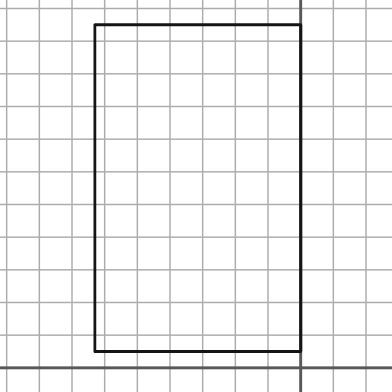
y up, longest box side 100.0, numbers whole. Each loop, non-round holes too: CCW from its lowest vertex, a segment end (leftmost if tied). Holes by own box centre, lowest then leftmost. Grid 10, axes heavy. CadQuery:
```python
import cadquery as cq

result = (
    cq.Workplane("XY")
    .moveTo(-63.0, 5.0)
    .lineTo(0.0, 5.0)
    .lineTo(0.0, 105.0)
    .lineTo(-63.0, 105.0)
    .close()
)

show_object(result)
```